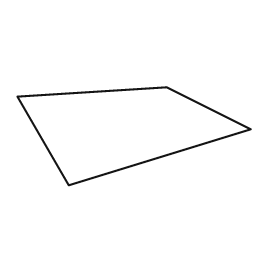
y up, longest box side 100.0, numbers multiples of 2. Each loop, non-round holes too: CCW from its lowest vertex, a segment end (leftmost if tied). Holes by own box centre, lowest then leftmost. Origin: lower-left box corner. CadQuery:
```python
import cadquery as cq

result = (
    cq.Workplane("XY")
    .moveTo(22.0, 0.0)
    .lineTo(100.0, 24.0)
    .lineTo(64.0, 42.0)
    .lineTo(0.0, 38.0)
    .close()
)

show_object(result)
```